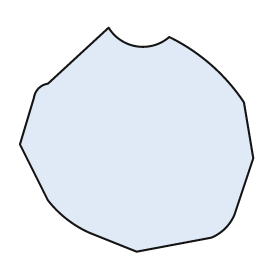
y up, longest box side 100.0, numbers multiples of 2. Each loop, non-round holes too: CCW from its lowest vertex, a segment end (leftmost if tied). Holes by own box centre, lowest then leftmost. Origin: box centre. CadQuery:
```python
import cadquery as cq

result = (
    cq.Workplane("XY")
    .moveTo(0.0, -48.0)
    .lineTo(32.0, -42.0)
    .threePointArc((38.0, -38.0), (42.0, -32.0))
    .lineTo(50.0, -8.0)
    .lineTo(46.0, 16.0)
    .threePointArc((32.0, 32.0), (14.0, 44.0))
    .threePointArc((0.0, 40.0), (-12.0, 48.0))
    .lineTo(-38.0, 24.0)
    .threePointArc((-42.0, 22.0), (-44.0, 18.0))
    .lineTo(-50.0, -2.0)
    .lineTo(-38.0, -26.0)
    .threePointArc((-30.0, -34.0), (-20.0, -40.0))
    .close()
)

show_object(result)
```